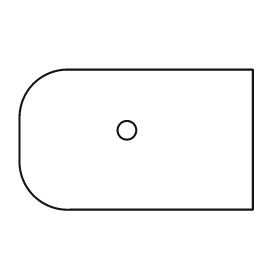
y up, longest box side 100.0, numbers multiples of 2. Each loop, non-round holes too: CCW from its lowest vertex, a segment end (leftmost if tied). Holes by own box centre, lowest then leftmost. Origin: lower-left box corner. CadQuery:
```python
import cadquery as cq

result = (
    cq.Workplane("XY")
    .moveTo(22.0, 0.0)
    .lineTo(100.0, 0.0)
    .lineTo(100.0, 60.0)
    .lineTo(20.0, 60.0)
    .threePointArc((6.0, 54.0), (0.0, 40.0))
    .lineTo(0.0, 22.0)
    .threePointArc((6.0, 6.0), (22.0, 0.0))
    .close()
    .moveTo(46.0, 34.0)
    .circle(4.0)
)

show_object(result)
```